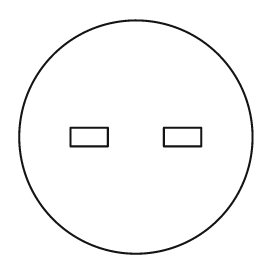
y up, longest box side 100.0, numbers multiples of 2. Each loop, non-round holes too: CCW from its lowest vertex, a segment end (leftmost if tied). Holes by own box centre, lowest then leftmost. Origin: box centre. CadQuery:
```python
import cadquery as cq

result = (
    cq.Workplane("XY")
    .moveTo(0.0, 0.0)
    .circle(50.0)
    .moveTo(-28.0, -4.0)
    .lineTo(-12.0, -4.0)
    .lineTo(-12.0, 4.0)
    .lineTo(-28.0, 4.0)
    .close()
    .moveTo(12.0, -4.0)
    .lineTo(28.0, -4.0)
    .lineTo(28.0, 4.0)
    .lineTo(12.0, 4.0)
    .close()
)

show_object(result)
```